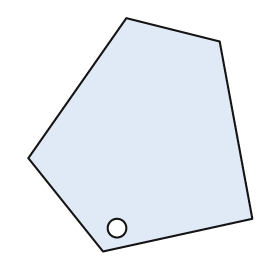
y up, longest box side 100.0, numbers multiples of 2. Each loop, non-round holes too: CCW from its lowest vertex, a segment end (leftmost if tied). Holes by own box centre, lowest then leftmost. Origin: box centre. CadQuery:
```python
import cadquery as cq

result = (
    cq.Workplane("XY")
    .moveTo(-16.0, -50.0)
    .lineTo(48.0, -36.0)
    .lineTo(34.0, 40.0)
    .lineTo(-6.0, 50.0)
    .lineTo(-48.0, -10.0)
    .close()
    .moveTo(-10.0, -40.0)
    .circle(4.0)
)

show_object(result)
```